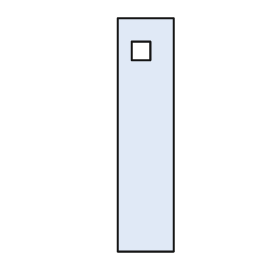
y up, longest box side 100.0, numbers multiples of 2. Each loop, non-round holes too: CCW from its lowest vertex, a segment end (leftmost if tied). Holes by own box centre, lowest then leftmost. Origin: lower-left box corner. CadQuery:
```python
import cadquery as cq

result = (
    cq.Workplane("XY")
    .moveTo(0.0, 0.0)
    .lineTo(24.0, 0.0)
    .lineTo(24.0, 100.0)
    .lineTo(0.0, 100.0)
    .close()
    .moveTo(6.0, 82.0)
    .lineTo(14.0, 82.0)
    .lineTo(14.0, 90.0)
    .lineTo(6.0, 90.0)
    .close()
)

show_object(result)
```